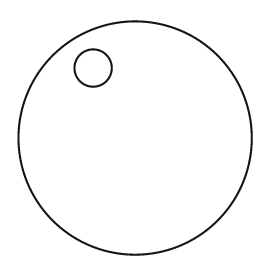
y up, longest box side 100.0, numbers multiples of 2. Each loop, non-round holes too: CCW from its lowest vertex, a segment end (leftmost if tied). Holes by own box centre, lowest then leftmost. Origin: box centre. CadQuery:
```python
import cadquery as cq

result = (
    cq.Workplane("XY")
    .moveTo(0.0, 0.0)
    .circle(50.0)
    .moveTo(-18.0, 30.0)
    .circle(8.0)
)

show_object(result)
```